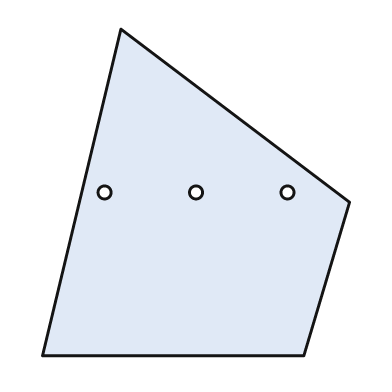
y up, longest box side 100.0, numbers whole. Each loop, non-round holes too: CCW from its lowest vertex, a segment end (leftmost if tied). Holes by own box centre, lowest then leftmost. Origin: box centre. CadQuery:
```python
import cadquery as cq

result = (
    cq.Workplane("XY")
    .moveTo(-47.0, -50.0)
    .lineTo(33.0, -50.0)
    .lineTo(47.0, -3.0)
    .lineTo(-23.0, 50.0)
    .close()
    .moveTo(-28.0, 0.0)
    .circle(2.0)
    .moveTo(0.0, 0.0)
    .circle(2.0)
    .moveTo(28.0, 0.0)
    .circle(2.0)
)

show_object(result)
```